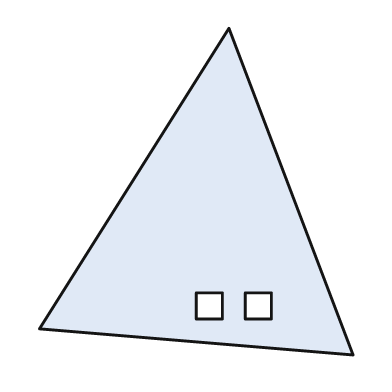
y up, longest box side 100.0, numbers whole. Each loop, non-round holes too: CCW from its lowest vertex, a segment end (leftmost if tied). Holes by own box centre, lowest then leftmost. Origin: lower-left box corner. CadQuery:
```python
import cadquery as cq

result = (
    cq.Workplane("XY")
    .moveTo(96.0, 0.0)
    .lineTo(58.0, 100.0)
    .lineTo(0.0, 8.0)
    .close()
    .moveTo(48.0, 11.0)
    .lineTo(56.0, 11.0)
    .lineTo(56.0, 19.0)
    .lineTo(48.0, 19.0)
    .close()
    .moveTo(63.0, 11.0)
    .lineTo(71.0, 11.0)
    .lineTo(71.0, 19.0)
    .lineTo(63.0, 19.0)
    .close()
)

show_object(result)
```